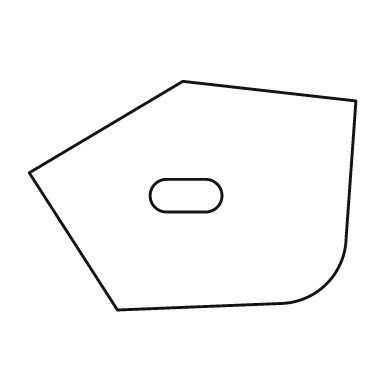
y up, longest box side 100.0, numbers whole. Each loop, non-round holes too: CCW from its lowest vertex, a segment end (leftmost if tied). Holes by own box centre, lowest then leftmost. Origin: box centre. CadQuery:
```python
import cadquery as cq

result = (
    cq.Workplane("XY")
    .moveTo(-23.0, -35.0)
    .lineTo(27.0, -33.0)
    .threePointArc((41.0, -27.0), (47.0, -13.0))
    .lineTo(50.0, 29.0)
    .lineTo(-3.0, 35.0)
    .lineTo(-50.0, 7.0)
    .close()
    .moveTo(-8.0, -5.0)
    .lineTo(4.0, -5.0)
    .threePointArc((9.0, 0.0), (4.0, 5.0))
    .lineTo(-8.0, 5.0)
    .threePointArc((-13.0, 0.0), (-8.0, -5.0))
    .close()
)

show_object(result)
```